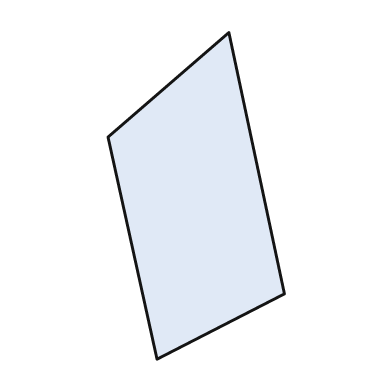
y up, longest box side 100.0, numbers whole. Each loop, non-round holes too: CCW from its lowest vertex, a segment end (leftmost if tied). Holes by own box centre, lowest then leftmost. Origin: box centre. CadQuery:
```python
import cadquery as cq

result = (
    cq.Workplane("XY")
    .moveTo(-12.0, -50.0)
    .lineTo(27.0, -30.0)
    .lineTo(10.0, 50.0)
    .lineTo(-27.0, 18.0)
    .close()
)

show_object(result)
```